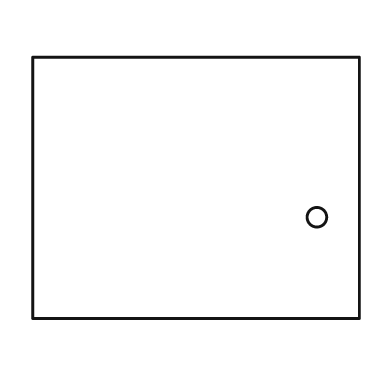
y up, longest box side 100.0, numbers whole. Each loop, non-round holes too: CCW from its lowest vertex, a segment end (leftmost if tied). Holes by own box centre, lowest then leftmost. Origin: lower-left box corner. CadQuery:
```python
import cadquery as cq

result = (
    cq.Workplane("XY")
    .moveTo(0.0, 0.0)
    .lineTo(100.0, 0.0)
    .lineTo(100.0, 80.0)
    .lineTo(0.0, 80.0)
    .close()
    .moveTo(87.0, 31.0)
    .circle(3.0)
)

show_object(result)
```